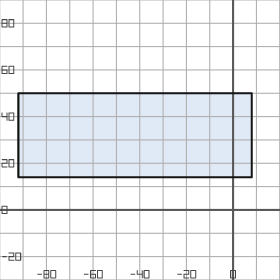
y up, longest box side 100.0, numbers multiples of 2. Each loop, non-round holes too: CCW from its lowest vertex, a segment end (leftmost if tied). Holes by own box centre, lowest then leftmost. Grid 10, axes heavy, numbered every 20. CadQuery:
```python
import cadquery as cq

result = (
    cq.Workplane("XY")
    .moveTo(-92.0, 14.0)
    .lineTo(8.0, 14.0)
    .lineTo(8.0, 50.0)
    .lineTo(-92.0, 50.0)
    .close()
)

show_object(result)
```